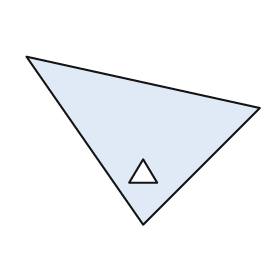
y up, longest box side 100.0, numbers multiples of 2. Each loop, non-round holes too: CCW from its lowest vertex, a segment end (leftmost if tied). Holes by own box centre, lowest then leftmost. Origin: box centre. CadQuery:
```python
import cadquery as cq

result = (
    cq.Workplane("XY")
    .moveTo(0.0, -36.0)
    .lineTo(50.0, 14.0)
    .lineTo(-50.0, 36.0)
    .close()
    .moveTo(-6.0, -18.0)
    .lineTo(6.0, -18.0)
    .lineTo(0.0, -8.0)
    .close()
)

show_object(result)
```